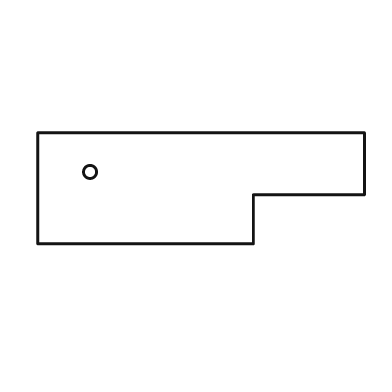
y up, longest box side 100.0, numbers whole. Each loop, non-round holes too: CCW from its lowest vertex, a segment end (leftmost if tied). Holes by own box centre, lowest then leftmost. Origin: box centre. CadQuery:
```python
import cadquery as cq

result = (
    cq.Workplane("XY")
    .moveTo(-50.0, -17.0)
    .lineTo(16.0, -17.0)
    .lineTo(16.0, -2.0)
    .lineTo(50.0, -2.0)
    .lineTo(50.0, 17.0)
    .lineTo(-50.0, 17.0)
    .close()
    .moveTo(-34.0, 5.0)
    .circle(2.0)
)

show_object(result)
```